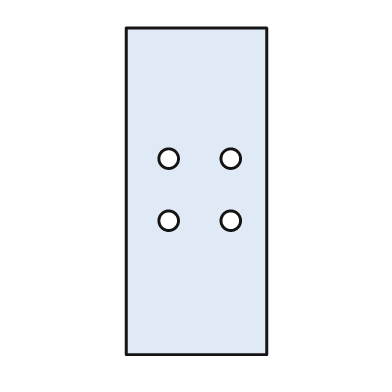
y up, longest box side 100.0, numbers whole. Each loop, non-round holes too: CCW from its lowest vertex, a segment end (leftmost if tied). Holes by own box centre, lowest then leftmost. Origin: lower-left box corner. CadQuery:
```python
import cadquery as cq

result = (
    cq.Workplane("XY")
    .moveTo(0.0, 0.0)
    .lineTo(43.0, 0.0)
    .lineTo(43.0, 100.0)
    .lineTo(0.0, 100.0)
    .close()
    .moveTo(13.0, 41.0)
    .circle(3.0)
    .moveTo(32.0, 41.0)
    .circle(3.0)
    .moveTo(13.0, 60.0)
    .circle(3.0)
    .moveTo(32.0, 60.0)
    .circle(3.0)
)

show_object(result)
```